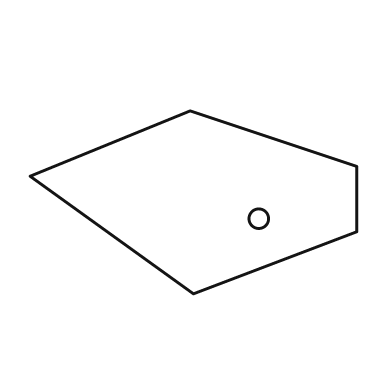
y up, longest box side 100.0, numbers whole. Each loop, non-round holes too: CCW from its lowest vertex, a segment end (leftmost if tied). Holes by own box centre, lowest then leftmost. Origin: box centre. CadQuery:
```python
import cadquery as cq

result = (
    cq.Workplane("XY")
    .moveTo(0.0, -28.0)
    .lineTo(50.0, -9.0)
    .lineTo(50.0, 11.0)
    .lineTo(-1.0, 28.0)
    .lineTo(-50.0, 8.0)
    .close()
    .moveTo(20.0, -5.0)
    .circle(3.0)
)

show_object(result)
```